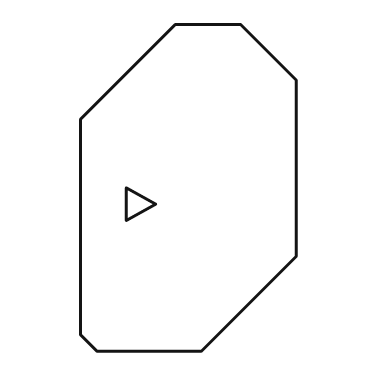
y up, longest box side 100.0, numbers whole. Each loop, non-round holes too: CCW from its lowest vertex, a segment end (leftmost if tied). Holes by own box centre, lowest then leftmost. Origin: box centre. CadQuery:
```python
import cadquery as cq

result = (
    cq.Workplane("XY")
    .moveTo(-28.0, -50.0)
    .lineTo(4.0, -50.0)
    .lineTo(33.0, -21.0)
    .lineTo(33.0, 33.0)
    .lineTo(16.0, 50.0)
    .lineTo(-4.0, 50.0)
    .lineTo(-33.0, 21.0)
    .lineTo(-33.0, -45.0)
    .close()
    .moveTo(-19.0, -10.0)
    .lineTo(-10.0, -5.0)
    .lineTo(-19.0, 0.0)
    .close()
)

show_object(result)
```